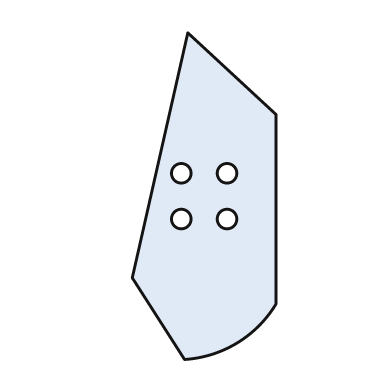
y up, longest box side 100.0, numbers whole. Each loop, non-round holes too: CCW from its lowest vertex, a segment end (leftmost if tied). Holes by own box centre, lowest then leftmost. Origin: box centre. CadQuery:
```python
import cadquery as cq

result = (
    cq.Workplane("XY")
    .moveTo(-6.0, -50.0)
    .threePointArc((10.0, -45.0), (22.0, -33.0))
    .lineTo(22.0, 25.0)
    .lineTo(-5.0, 50.0)
    .lineTo(-22.0, -25.0)
    .close()
    .moveTo(-7.0, -7.0)
    .circle(3.0)
    .moveTo(7.0, -7.0)
    .circle(3.0)
    .moveTo(-7.0, 7.0)
    .circle(3.0)
    .moveTo(7.0, 7.0)
    .circle(3.0)
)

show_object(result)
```